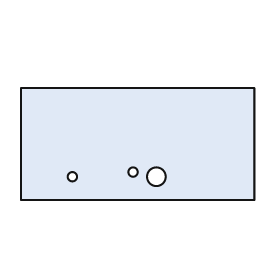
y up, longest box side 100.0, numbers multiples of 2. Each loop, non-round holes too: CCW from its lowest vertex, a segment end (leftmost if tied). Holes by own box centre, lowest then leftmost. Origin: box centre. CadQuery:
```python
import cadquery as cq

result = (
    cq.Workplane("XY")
    .moveTo(-50.0, -24.0)
    .lineTo(50.0, -24.0)
    .lineTo(50.0, 24.0)
    .lineTo(-50.0, 24.0)
    .close()
    .moveTo(-28.0, -14.0)
    .circle(2.0)
    .moveTo(8.0, -14.0)
    .circle(4.0)
    .moveTo(-2.0, -12.0)
    .circle(2.0)
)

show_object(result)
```